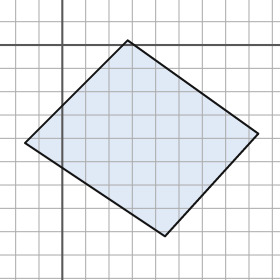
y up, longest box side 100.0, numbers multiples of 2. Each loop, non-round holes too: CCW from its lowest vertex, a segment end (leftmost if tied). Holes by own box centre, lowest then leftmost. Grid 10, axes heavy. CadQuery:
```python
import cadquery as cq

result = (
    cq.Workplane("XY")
    .moveTo(44.0, -82.0)
    .lineTo(84.0, -38.0)
    .lineTo(28.0, 2.0)
    .lineTo(-16.0, -42.0)
    .close()
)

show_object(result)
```